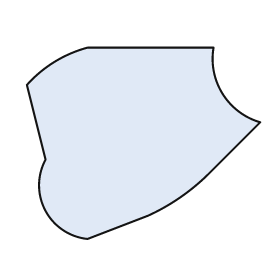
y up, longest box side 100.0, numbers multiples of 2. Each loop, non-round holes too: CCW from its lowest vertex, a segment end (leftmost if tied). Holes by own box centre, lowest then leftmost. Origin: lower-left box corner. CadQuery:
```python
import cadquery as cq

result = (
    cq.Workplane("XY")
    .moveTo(26.0, 0.0)
    .lineTo(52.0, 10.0)
    .threePointArc((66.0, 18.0), (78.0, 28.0))
    .lineTo(100.0, 50.0)
    .threePointArc((84.0, 62.0), (80.0, 82.0))
    .lineTo(26.0, 82.0)
    .threePointArc((12.0, 76.0), (0.0, 66.0))
    .lineTo(8.0, 34.0)
    .threePointArc((8.0, 12.0), (26.0, 0.0))
    .close()
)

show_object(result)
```